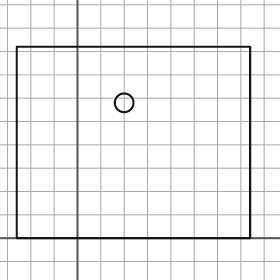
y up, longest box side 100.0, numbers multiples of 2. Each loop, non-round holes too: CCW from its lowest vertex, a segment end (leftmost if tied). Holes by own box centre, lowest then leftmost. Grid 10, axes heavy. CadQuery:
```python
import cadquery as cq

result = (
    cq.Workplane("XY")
    .moveTo(-26.0, 0.0)
    .lineTo(74.0, 0.0)
    .lineTo(74.0, 82.0)
    .lineTo(-26.0, 82.0)
    .close()
    .moveTo(20.0, 58.0)
    .circle(4.0)
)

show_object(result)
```